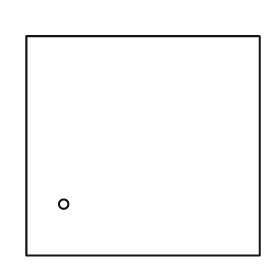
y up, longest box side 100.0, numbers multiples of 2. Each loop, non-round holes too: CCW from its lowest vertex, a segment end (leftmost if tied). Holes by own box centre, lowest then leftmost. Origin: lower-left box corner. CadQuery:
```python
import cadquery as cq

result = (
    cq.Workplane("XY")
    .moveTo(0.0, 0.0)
    .lineTo(100.0, 0.0)
    .lineTo(100.0, 94.0)
    .lineTo(0.0, 94.0)
    .close()
    .moveTo(16.0, 22.0)
    .circle(2.0)
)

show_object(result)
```